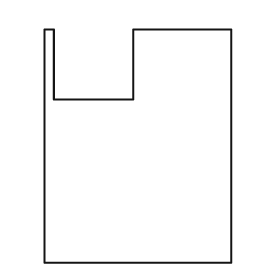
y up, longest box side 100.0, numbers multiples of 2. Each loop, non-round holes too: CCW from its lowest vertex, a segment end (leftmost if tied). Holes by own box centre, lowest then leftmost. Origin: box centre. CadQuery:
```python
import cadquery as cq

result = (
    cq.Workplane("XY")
    .moveTo(-40.0, -50.0)
    .lineTo(40.0, -50.0)
    .lineTo(40.0, 50.0)
    .lineTo(-2.0, 50.0)
    .lineTo(-2.0, 20.0)
    .lineTo(-36.0, 20.0)
    .lineTo(-36.0, 50.0)
    .lineTo(-40.0, 50.0)
    .close()
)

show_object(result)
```